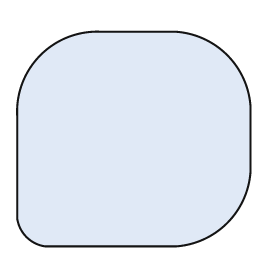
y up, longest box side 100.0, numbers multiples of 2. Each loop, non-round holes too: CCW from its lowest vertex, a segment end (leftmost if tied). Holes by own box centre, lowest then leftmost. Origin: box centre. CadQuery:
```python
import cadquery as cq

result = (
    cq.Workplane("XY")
    .moveTo(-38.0, -46.0)
    .lineTo(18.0, -46.0)
    .threePointArc((40.0, -36.0), (50.0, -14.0))
    .lineTo(50.0, 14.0)
    .threePointArc((40.0, 36.0), (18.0, 46.0))
    .lineTo(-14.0, 46.0)
    .threePointArc((-40.0, 36.0), (-50.0, 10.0))
    .lineTo(-50.0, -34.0)
    .threePointArc((-46.0, -42.0), (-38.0, -46.0))
    .close()
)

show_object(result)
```